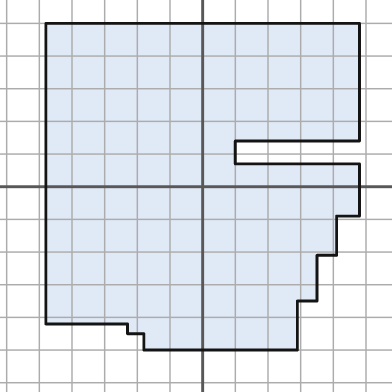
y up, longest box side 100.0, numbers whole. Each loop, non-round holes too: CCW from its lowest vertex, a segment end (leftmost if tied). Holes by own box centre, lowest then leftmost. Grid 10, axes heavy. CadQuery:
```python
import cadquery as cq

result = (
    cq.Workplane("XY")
    .moveTo(-18.0, -50.0)
    .lineTo(29.0, -50.0)
    .lineTo(29.0, -35.0)
    .lineTo(35.0, -35.0)
    .lineTo(35.0, -21.0)
    .lineTo(41.0, -21.0)
    .lineTo(41.0, -9.0)
    .lineTo(48.0, -9.0)
    .lineTo(48.0, 7.0)
    .lineTo(10.0, 7.0)
    .lineTo(10.0, 14.0)
    .lineTo(48.0, 14.0)
    .lineTo(48.0, 50.0)
    .lineTo(-48.0, 50.0)
    .lineTo(-48.0, -42.0)
    .lineTo(-23.0, -42.0)
    .lineTo(-23.0, -45.0)
    .lineTo(-18.0, -45.0)
    .close()
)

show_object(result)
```